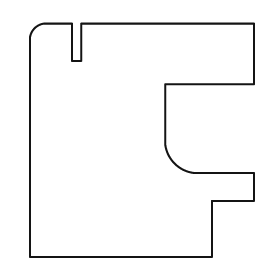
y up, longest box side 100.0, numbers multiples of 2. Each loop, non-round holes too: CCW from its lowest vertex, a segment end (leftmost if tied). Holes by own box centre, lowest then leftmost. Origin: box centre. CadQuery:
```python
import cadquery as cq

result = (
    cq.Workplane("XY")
    .moveTo(-48.0, -50.0)
    .lineTo(30.0, -50.0)
    .lineTo(30.0, -26.0)
    .lineTo(48.0, -26.0)
    .lineTo(48.0, -14.0)
    .lineTo(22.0, -14.0)
    .threePointArc((14.0, -10.0), (10.0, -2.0))
    .lineTo(10.0, 24.0)
    .lineTo(48.0, 24.0)
    .lineTo(48.0, 50.0)
    .lineTo(-26.0, 50.0)
    .lineTo(-26.0, 34.0)
    .lineTo(-30.0, 34.0)
    .lineTo(-30.0, 50.0)
    .lineTo(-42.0, 50.0)
    .threePointArc((-46.0, 48.0), (-48.0, 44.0))
    .close()
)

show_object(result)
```